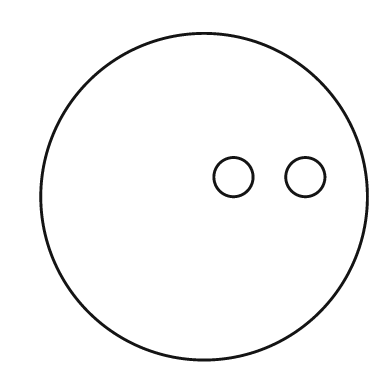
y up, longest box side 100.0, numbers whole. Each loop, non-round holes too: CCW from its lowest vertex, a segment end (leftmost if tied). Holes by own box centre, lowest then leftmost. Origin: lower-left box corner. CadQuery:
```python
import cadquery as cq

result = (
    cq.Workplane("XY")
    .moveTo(50.0, 50.0)
    .circle(50.0)
    .moveTo(59.0, 56.0)
    .circle(6.0)
    .moveTo(81.0, 56.0)
    .circle(6.0)
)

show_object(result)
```